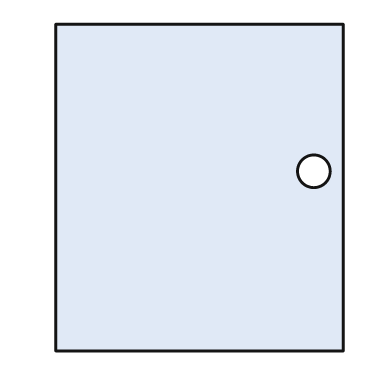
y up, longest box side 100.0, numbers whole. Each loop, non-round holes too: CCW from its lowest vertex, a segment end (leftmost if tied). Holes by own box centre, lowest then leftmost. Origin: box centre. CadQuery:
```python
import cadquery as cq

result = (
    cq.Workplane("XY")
    .moveTo(-44.0, -50.0)
    .lineTo(44.0, -50.0)
    .lineTo(44.0, 50.0)
    .lineTo(-44.0, 50.0)
    .close()
    .moveTo(35.0, 5.0)
    .circle(5.0)
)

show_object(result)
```